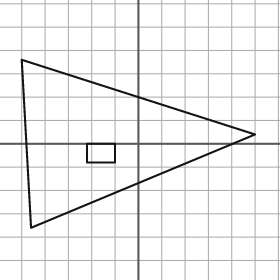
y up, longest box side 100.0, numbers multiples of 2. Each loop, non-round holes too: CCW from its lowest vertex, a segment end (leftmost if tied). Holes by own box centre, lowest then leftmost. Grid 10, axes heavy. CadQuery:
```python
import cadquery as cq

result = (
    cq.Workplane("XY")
    .moveTo(-46.0, -36.0)
    .lineTo(50.0, 4.0)
    .lineTo(-50.0, 36.0)
    .close()
    .moveTo(-22.0, -8.0)
    .lineTo(-10.0, -8.0)
    .lineTo(-10.0, 0.0)
    .lineTo(-22.0, 0.0)
    .close()
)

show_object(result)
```